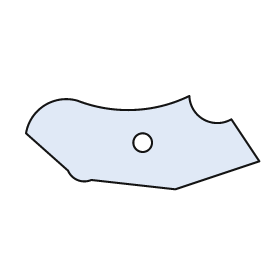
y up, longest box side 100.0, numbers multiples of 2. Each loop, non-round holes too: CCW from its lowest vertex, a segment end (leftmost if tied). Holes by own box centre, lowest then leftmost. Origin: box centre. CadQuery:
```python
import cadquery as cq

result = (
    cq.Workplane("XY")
    .moveTo(14.0, -20.0)
    .lineTo(50.0, -8.0)
    .lineTo(38.0, 10.0)
    .threePointArc((26.0, 10.0), (20.0, 20.0))
    .threePointArc((-4.0, 14.0), (-28.0, 18.0))
    .threePointArc((-42.0, 16.0), (-50.0, 4.0))
    .lineTo(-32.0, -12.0)
    .threePointArc((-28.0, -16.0), (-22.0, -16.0))
    .close()
    .moveTo(0.0, 0.0)
    .circle(4.0)
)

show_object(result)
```